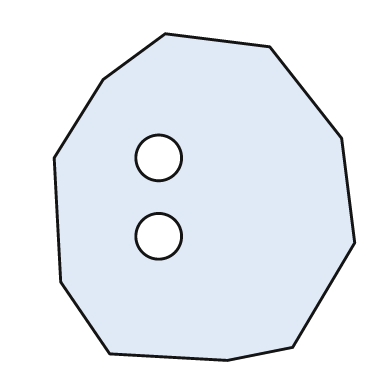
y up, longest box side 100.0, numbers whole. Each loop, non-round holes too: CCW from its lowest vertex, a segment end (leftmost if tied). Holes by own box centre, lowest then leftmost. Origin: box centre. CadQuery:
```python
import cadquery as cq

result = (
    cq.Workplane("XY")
    .moveTo(7.0, -50.0)
    .lineTo(27.0, -46.0)
    .lineTo(46.0, -14.0)
    .lineTo(42.0, 18.0)
    .lineTo(20.0, 46.0)
    .lineTo(-12.0, 50.0)
    .lineTo(-31.0, 36.0)
    .lineTo(-46.0, 12.0)
    .lineTo(-44.0, -26.0)
    .lineTo(-29.0, -48.0)
    .close()
    .moveTo(-14.0, -12.0)
    .circle(7.0)
    .moveTo(-14.0, 12.0)
    .circle(7.0)
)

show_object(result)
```